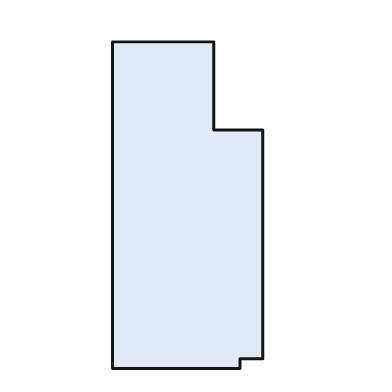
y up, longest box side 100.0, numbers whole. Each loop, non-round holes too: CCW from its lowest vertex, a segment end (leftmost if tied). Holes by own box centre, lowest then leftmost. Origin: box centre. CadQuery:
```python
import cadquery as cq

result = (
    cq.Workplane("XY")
    .moveTo(-23.0, -50.0)
    .lineTo(16.0, -50.0)
    .lineTo(16.0, -47.0)
    .lineTo(23.0, -47.0)
    .lineTo(23.0, 23.0)
    .lineTo(8.0, 23.0)
    .lineTo(8.0, 50.0)
    .lineTo(-23.0, 50.0)
    .close()
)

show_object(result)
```